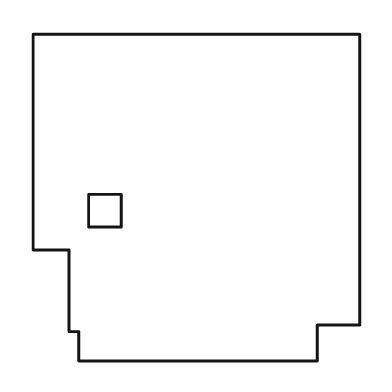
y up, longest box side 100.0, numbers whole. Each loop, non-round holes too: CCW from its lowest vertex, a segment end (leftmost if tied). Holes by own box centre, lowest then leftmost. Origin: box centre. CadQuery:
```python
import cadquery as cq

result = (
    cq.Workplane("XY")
    .moveTo(-36.0, -50.0)
    .lineTo(37.0, -50.0)
    .lineTo(37.0, -39.0)
    .lineTo(50.0, -39.0)
    .lineTo(50.0, 50.0)
    .lineTo(-50.0, 50.0)
    .lineTo(-50.0, -16.0)
    .lineTo(-39.0, -16.0)
    .lineTo(-39.0, -41.0)
    .lineTo(-36.0, -41.0)
    .close()
    .moveTo(-33.0, -9.0)
    .lineTo(-23.0, -9.0)
    .lineTo(-23.0, 1.0)
    .lineTo(-33.0, 1.0)
    .close()
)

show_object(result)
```